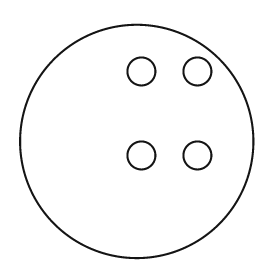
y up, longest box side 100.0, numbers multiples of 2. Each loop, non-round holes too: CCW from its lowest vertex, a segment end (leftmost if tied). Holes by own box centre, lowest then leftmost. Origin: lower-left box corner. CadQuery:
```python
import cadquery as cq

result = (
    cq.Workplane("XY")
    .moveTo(50.0, 50.0)
    .circle(50.0)
    .moveTo(52.0, 44.0)
    .circle(6.0)
    .moveTo(76.0, 44.0)
    .circle(6.0)
    .moveTo(52.0, 80.0)
    .circle(6.0)
    .moveTo(76.0, 80.0)
    .circle(6.0)
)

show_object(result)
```